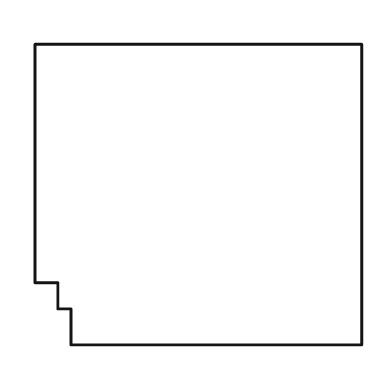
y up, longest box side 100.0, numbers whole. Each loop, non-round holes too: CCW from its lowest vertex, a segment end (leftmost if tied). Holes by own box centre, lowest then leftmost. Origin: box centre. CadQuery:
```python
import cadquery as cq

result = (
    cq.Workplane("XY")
    .moveTo(-39.0, -46.0)
    .lineTo(50.0, -46.0)
    .lineTo(50.0, 46.0)
    .lineTo(-50.0, 46.0)
    .lineTo(-50.0, -27.0)
    .lineTo(-43.0, -27.0)
    .lineTo(-43.0, -35.0)
    .lineTo(-39.0, -35.0)
    .close()
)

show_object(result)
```